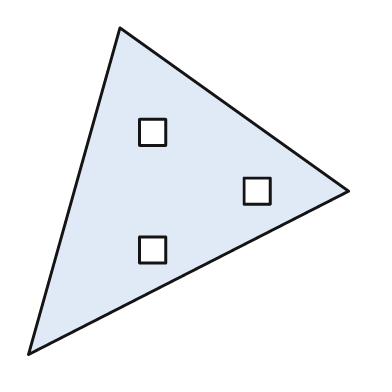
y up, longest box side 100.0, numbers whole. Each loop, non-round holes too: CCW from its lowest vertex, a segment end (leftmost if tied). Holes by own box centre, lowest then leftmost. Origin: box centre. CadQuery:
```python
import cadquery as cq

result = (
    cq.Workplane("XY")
    .moveTo(-49.0, -50.0)
    .lineTo(49.0, 0.0)
    .lineTo(-21.0, 50.0)
    .close()
    .moveTo(-15.0, -22.0)
    .lineTo(-7.0, -22.0)
    .lineTo(-7.0, -14.0)
    .lineTo(-15.0, -14.0)
    .close()
    .moveTo(17.0, -4.0)
    .lineTo(25.0, -4.0)
    .lineTo(25.0, 4.0)
    .lineTo(17.0, 4.0)
    .close()
    .moveTo(-15.0, 14.0)
    .lineTo(-7.0, 14.0)
    .lineTo(-7.0, 22.0)
    .lineTo(-15.0, 22.0)
    .close()
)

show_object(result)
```